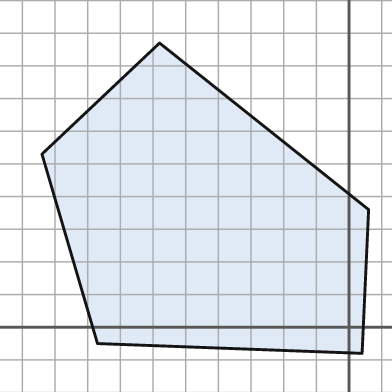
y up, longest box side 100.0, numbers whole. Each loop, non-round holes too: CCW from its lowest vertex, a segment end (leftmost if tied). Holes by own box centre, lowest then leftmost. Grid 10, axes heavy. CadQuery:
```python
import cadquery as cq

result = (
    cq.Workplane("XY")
    .moveTo(4.0, -8.0)
    .lineTo(6.0, 36.0)
    .lineTo(-58.0, 87.0)
    .lineTo(-94.0, 53.0)
    .lineTo(-77.0, -5.0)
    .close()
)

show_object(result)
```